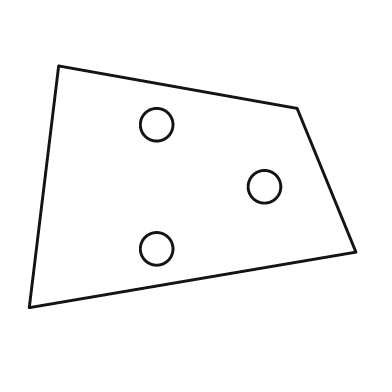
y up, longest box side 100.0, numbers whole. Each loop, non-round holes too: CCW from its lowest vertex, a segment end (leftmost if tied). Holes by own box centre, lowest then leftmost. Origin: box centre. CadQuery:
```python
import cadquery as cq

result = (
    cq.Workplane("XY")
    .moveTo(-50.0, -37.0)
    .lineTo(50.0, -20.0)
    .lineTo(32.0, 24.0)
    .lineTo(-41.0, 37.0)
    .close()
    .moveTo(-11.0, -19.0)
    .circle(5.0)
    .moveTo(22.0, 0.0)
    .circle(5.0)
    .moveTo(-11.0, 19.0)
    .circle(5.0)
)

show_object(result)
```